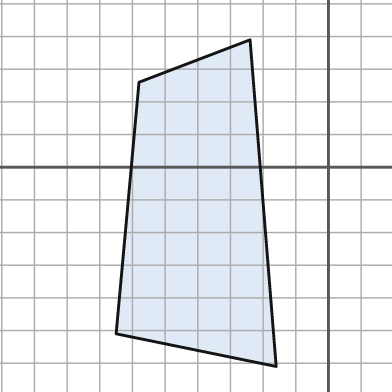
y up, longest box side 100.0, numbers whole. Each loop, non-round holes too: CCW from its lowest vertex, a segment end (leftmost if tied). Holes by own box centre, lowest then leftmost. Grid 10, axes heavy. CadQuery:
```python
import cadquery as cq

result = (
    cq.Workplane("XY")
    .moveTo(-16.0, -61.0)
    .lineTo(-24.0, 39.0)
    .lineTo(-58.0, 26.0)
    .lineTo(-65.0, -51.0)
    .close()
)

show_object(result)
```